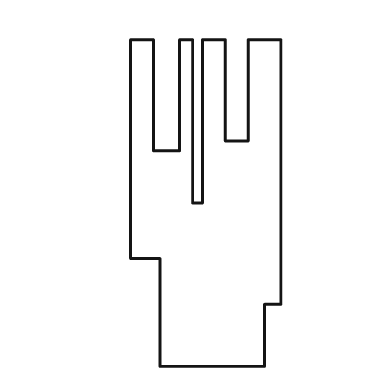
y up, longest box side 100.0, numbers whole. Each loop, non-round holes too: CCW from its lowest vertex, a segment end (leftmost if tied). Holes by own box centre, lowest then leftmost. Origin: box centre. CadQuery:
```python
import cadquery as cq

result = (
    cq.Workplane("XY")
    .moveTo(-14.0, -50.0)
    .lineTo(18.0, -50.0)
    .lineTo(18.0, -31.0)
    .lineTo(23.0, -31.0)
    .lineTo(23.0, 50.0)
    .lineTo(13.0, 50.0)
    .lineTo(13.0, 19.0)
    .lineTo(6.0, 19.0)
    .lineTo(6.0, 50.0)
    .lineTo(-1.0, 50.0)
    .lineTo(-1.0, 0.0)
    .lineTo(-4.0, 0.0)
    .lineTo(-4.0, 50.0)
    .lineTo(-8.0, 50.0)
    .lineTo(-8.0, 16.0)
    .lineTo(-16.0, 16.0)
    .lineTo(-16.0, 50.0)
    .lineTo(-23.0, 50.0)
    .lineTo(-23.0, -17.0)
    .lineTo(-14.0, -17.0)
    .close()
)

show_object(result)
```